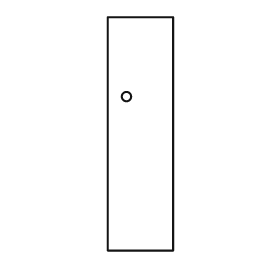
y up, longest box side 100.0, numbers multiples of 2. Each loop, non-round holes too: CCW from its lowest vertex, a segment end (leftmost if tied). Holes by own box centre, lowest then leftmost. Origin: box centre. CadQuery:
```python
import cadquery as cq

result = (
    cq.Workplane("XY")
    .moveTo(-14.0, -50.0)
    .lineTo(14.0, -50.0)
    .lineTo(14.0, 50.0)
    .lineTo(-14.0, 50.0)
    .close()
    .moveTo(-6.0, 16.0)
    .circle(2.0)
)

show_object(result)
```